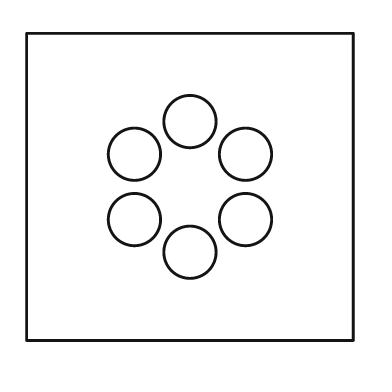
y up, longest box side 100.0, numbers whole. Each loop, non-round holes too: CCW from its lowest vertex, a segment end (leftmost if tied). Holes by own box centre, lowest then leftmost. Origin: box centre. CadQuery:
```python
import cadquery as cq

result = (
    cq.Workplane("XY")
    .moveTo(-50.0, -47.0)
    .lineTo(50.0, -47.0)
    .lineTo(50.0, 47.0)
    .lineTo(-50.0, 47.0)
    .close()
    .moveTo(0.0, -20.0)
    .circle(8.0)
    .moveTo(-17.0, -10.0)
    .circle(8.0)
    .moveTo(17.0, -10.0)
    .circle(8.0)
    .moveTo(-17.0, 10.0)
    .circle(8.0)
    .moveTo(17.0, 10.0)
    .circle(8.0)
    .moveTo(0.0, 20.0)
    .circle(8.0)
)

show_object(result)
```